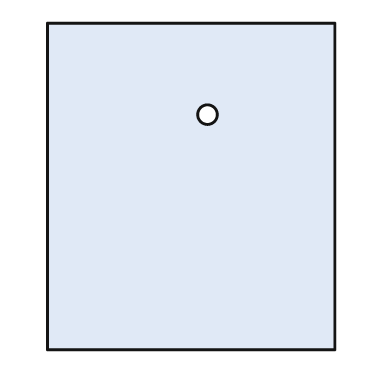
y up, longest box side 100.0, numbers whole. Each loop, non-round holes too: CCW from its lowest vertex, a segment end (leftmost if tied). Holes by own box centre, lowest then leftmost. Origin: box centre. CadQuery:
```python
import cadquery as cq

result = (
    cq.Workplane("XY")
    .moveTo(-44.0, -50.0)
    .lineTo(44.0, -50.0)
    .lineTo(44.0, 50.0)
    .lineTo(-44.0, 50.0)
    .close()
    .moveTo(5.0, 22.0)
    .circle(3.0)
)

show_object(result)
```